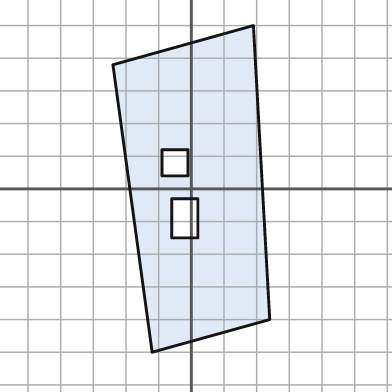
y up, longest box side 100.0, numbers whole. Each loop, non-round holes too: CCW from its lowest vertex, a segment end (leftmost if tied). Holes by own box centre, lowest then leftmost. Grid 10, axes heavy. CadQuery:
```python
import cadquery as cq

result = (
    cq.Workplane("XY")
    .moveTo(-12.0, -50.0)
    .lineTo(24.0, -40.0)
    .lineTo(19.0, 50.0)
    .lineTo(-24.0, 38.0)
    .close()
    .moveTo(-6.0, -15.0)
    .lineTo(2.0, -15.0)
    .lineTo(2.0, -3.0)
    .lineTo(-6.0, -3.0)
    .close()
    .moveTo(-9.0, 4.0)
    .lineTo(-1.0, 4.0)
    .lineTo(-1.0, 12.0)
    .lineTo(-9.0, 12.0)
    .close()
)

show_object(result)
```